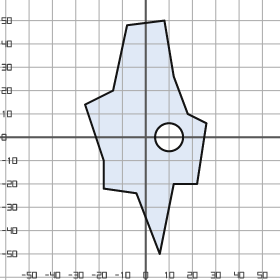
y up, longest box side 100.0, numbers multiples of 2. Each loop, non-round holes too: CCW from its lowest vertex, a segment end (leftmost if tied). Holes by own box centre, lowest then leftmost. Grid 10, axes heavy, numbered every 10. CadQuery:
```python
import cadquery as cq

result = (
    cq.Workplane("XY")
    .moveTo(6.0, -50.0)
    .lineTo(12.0, -20.0)
    .lineTo(22.0, -20.0)
    .lineTo(26.0, 6.0)
    .lineTo(18.0, 10.0)
    .lineTo(12.0, 26.0)
    .lineTo(8.0, 50.0)
    .lineTo(-8.0, 48.0)
    .lineTo(-14.0, 20.0)
    .lineTo(-26.0, 14.0)
    .lineTo(-18.0, -10.0)
    .lineTo(-18.0, -22.0)
    .lineTo(-4.0, -24.0)
    .close()
    .moveTo(10.0, 0.0)
    .circle(6.0)
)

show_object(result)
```